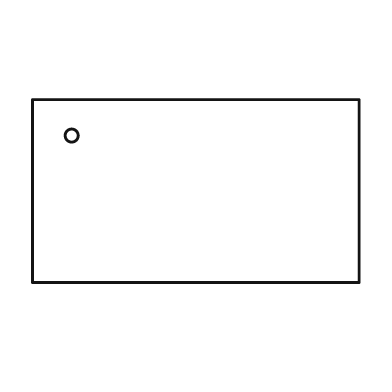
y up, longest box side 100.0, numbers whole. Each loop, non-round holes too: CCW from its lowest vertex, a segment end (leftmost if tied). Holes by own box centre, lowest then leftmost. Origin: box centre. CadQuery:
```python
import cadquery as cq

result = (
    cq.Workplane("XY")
    .moveTo(-50.0, -28.0)
    .lineTo(50.0, -28.0)
    .lineTo(50.0, 28.0)
    .lineTo(-50.0, 28.0)
    .close()
    .moveTo(-38.0, 17.0)
    .circle(2.0)
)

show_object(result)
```